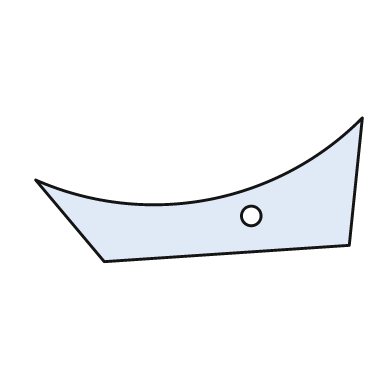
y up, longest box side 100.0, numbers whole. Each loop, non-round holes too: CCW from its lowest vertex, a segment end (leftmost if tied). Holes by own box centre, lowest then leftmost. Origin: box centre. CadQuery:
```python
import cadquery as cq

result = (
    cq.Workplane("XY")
    .moveTo(-29.0, -22.0)
    .lineTo(46.0, -17.0)
    .lineTo(50.0, 22.0)
    .threePointArc((3.0, -3.0), (-50.0, 3.0))
    .close()
    .moveTo(16.0, -8.0)
    .circle(3.0)
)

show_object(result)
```